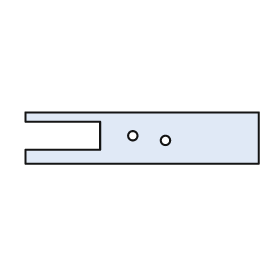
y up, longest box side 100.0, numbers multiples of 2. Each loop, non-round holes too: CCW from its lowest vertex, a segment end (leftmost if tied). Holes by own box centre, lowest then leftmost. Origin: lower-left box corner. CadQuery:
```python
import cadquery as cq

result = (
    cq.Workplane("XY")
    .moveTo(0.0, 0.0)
    .lineTo(100.0, 0.0)
    .lineTo(100.0, 22.0)
    .lineTo(0.0, 22.0)
    .lineTo(0.0, 18.0)
    .lineTo(32.0, 18.0)
    .lineTo(32.0, 6.0)
    .lineTo(0.0, 6.0)
    .close()
    .moveTo(60.0, 10.0)
    .circle(2.0)
    .moveTo(46.0, 12.0)
    .circle(2.0)
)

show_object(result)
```